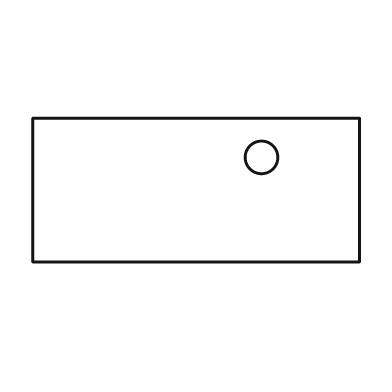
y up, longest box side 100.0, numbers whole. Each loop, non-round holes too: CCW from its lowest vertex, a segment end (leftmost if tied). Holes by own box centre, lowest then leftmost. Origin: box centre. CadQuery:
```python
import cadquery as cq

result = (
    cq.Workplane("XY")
    .moveTo(-50.0, -22.0)
    .lineTo(50.0, -22.0)
    .lineTo(50.0, 22.0)
    .lineTo(-50.0, 22.0)
    .close()
    .moveTo(20.0, 10.0)
    .circle(5.0)
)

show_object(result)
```